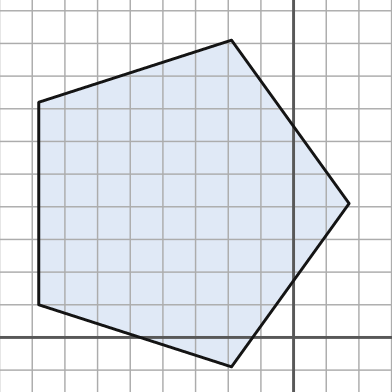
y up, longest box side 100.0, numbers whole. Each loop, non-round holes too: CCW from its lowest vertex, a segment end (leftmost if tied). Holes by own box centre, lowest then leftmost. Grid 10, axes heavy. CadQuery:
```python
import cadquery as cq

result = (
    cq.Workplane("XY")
    .moveTo(-19.0, -9.0)
    .lineTo(17.0, 41.0)
    .lineTo(-19.0, 91.0)
    .lineTo(-78.0, 72.0)
    .lineTo(-78.0, 10.0)
    .close()
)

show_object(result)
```